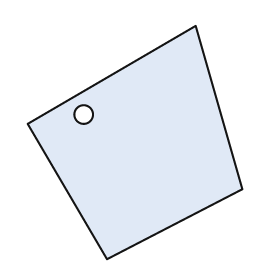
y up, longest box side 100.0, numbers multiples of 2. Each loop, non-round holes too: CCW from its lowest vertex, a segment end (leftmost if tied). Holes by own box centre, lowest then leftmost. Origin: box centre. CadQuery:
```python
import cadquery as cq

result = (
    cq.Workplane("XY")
    .moveTo(-12.0, -50.0)
    .lineTo(46.0, -20.0)
    .lineTo(26.0, 50.0)
    .lineTo(-46.0, 8.0)
    .close()
    .moveTo(-22.0, 12.0)
    .circle(4.0)
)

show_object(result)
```